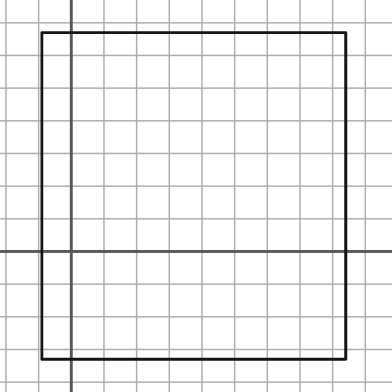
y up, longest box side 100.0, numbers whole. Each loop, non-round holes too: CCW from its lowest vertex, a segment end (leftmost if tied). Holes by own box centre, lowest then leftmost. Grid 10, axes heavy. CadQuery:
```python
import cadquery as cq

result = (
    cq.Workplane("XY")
    .moveTo(-9.0, -33.0)
    .lineTo(84.0, -33.0)
    .lineTo(84.0, 67.0)
    .lineTo(-9.0, 67.0)
    .close()
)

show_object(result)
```